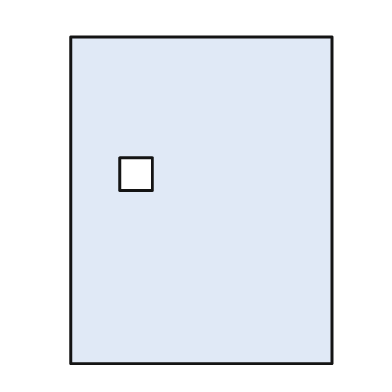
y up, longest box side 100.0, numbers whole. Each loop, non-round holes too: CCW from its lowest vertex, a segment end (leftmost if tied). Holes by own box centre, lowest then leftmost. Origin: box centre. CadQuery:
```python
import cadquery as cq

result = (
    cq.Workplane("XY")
    .moveTo(-40.0, -50.0)
    .lineTo(40.0, -50.0)
    .lineTo(40.0, 50.0)
    .lineTo(-40.0, 50.0)
    .close()
    .moveTo(-25.0, 3.0)
    .lineTo(-15.0, 3.0)
    .lineTo(-15.0, 13.0)
    .lineTo(-25.0, 13.0)
    .close()
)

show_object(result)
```